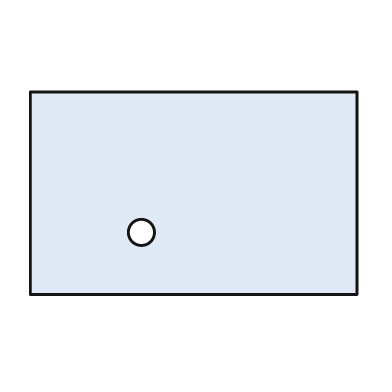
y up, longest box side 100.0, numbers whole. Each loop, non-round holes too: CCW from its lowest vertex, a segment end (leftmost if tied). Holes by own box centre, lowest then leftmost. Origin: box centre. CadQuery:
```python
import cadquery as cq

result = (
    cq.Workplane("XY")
    .moveTo(-50.0, -31.0)
    .lineTo(50.0, -31.0)
    .lineTo(50.0, 31.0)
    .lineTo(-50.0, 31.0)
    .close()
    .moveTo(-16.0, -12.0)
    .circle(4.0)
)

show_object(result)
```